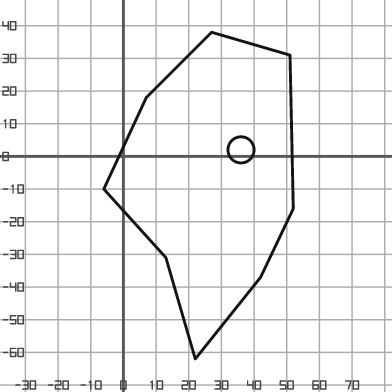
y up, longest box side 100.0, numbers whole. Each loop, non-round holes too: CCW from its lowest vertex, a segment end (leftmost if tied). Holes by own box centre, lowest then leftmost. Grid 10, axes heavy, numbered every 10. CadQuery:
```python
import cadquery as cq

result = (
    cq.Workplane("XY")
    .moveTo(22.0, -62.0)
    .lineTo(42.0, -37.0)
    .lineTo(52.0, -16.0)
    .lineTo(51.0, 31.0)
    .lineTo(27.0, 38.0)
    .lineTo(7.0, 18.0)
    .lineTo(-6.0, -10.0)
    .lineTo(13.0, -31.0)
    .close()
    .moveTo(36.0, 2.0)
    .circle(4.0)
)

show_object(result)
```